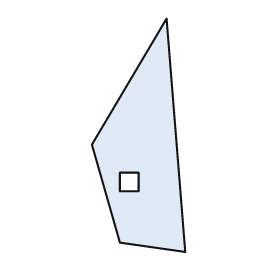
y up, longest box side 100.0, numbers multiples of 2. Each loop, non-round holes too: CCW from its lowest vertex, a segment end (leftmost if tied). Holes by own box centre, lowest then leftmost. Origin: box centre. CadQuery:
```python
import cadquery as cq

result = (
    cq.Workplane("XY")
    .moveTo(20.0, -50.0)
    .lineTo(12.0, 50.0)
    .lineTo(-20.0, -4.0)
    .lineTo(-8.0, -46.0)
    .close()
    .moveTo(-8.0, -24.0)
    .lineTo(0.0, -24.0)
    .lineTo(0.0, -16.0)
    .lineTo(-8.0, -16.0)
    .close()
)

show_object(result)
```